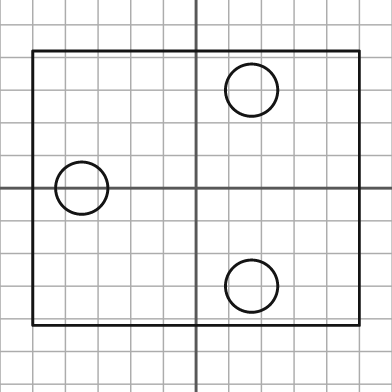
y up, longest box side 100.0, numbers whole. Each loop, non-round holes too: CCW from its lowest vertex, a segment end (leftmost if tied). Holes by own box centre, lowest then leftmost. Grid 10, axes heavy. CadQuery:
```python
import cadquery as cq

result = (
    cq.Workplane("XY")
    .moveTo(-50.0, -42.0)
    .lineTo(50.0, -42.0)
    .lineTo(50.0, 42.0)
    .lineTo(-50.0, 42.0)
    .close()
    .moveTo(17.0, -30.0)
    .circle(8.0)
    .moveTo(-35.0, 0.0)
    .circle(8.0)
    .moveTo(17.0, 30.0)
    .circle(8.0)
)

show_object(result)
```